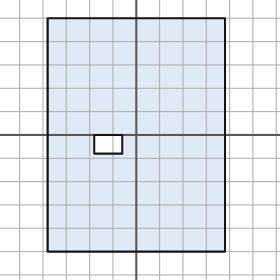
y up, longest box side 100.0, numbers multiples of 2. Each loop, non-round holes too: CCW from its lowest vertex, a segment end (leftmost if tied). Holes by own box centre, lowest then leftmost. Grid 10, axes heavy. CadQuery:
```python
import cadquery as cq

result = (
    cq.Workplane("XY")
    .moveTo(-38.0, -50.0)
    .lineTo(38.0, -50.0)
    .lineTo(38.0, 50.0)
    .lineTo(-38.0, 50.0)
    .close()
    .moveTo(-18.0, -8.0)
    .lineTo(-6.0, -8.0)
    .lineTo(-6.0, 0.0)
    .lineTo(-18.0, 0.0)
    .close()
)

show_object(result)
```